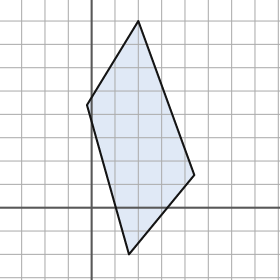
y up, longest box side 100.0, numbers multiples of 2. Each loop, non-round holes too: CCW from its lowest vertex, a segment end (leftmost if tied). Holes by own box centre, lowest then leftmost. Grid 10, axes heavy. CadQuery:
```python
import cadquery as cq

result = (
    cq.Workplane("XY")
    .moveTo(16.0, -20.0)
    .lineTo(44.0, 14.0)
    .lineTo(20.0, 80.0)
    .lineTo(-2.0, 44.0)
    .close()
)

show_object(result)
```